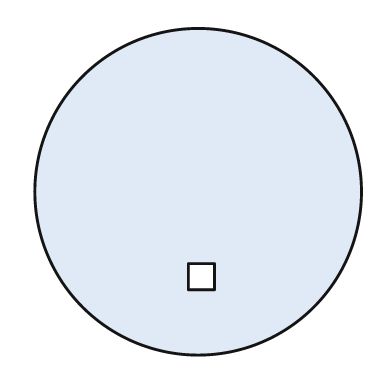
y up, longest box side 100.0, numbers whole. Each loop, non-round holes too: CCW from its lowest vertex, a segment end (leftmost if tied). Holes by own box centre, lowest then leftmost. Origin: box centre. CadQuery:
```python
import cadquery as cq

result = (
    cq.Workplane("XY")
    .moveTo(0.0, 0.0)
    .circle(50.0)
    .moveTo(-3.0, -30.0)
    .lineTo(5.0, -30.0)
    .lineTo(5.0, -22.0)
    .lineTo(-3.0, -22.0)
    .close()
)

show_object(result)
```